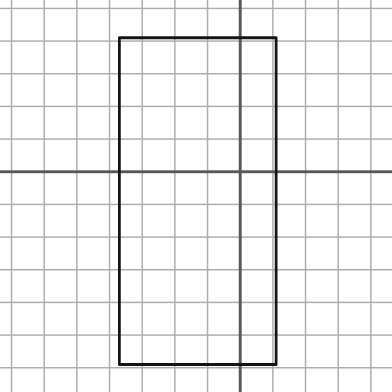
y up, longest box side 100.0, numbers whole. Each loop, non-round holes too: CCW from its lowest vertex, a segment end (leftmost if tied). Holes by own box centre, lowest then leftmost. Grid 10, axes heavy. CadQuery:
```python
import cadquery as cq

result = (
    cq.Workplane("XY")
    .moveTo(-37.0, -59.0)
    .lineTo(11.0, -59.0)
    .lineTo(11.0, 41.0)
    .lineTo(-37.0, 41.0)
    .close()
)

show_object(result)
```